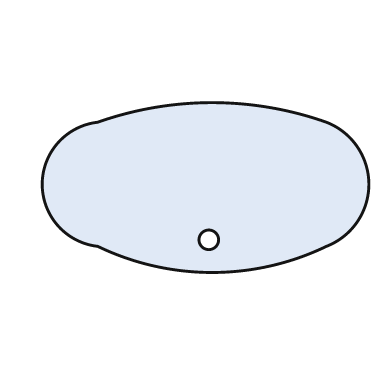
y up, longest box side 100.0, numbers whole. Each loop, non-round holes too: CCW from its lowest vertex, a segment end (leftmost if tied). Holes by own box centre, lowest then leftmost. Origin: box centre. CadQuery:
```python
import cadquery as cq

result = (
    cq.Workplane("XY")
    .moveTo(-33.0, -18.0)
    .threePointArc((2.0, -26.0), (37.0, -18.0))
    .threePointArc((50.0, 1.0), (37.0, 20.0))
    .threePointArc((2.0, 26.0), (-33.0, 20.0))
    .threePointArc((-50.0, 1.0), (-33.0, -18.0))
    .close()
    .moveTo(1.0, -16.0)
    .circle(3.0)
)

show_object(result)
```